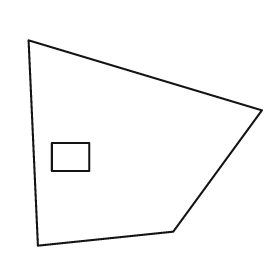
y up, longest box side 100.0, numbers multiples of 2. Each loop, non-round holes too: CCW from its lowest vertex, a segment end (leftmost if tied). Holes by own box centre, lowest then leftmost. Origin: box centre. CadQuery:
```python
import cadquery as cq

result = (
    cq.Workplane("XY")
    .moveTo(-46.0, -44.0)
    .lineTo(12.0, -38.0)
    .lineTo(50.0, 14.0)
    .lineTo(-50.0, 44.0)
    .close()
    .moveTo(-40.0, -12.0)
    .lineTo(-24.0, -12.0)
    .lineTo(-24.0, 0.0)
    .lineTo(-40.0, 0.0)
    .close()
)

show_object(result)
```